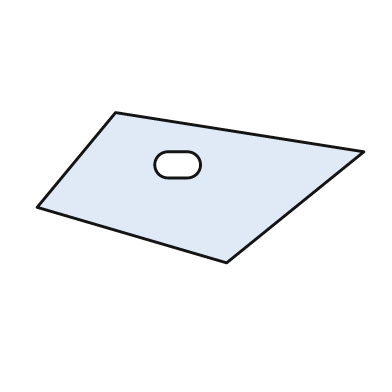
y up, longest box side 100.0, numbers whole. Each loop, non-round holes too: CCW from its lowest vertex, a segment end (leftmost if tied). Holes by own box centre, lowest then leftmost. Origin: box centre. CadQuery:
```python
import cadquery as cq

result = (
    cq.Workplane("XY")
    .moveTo(8.0, -23.0)
    .lineTo(50.0, 11.0)
    .lineTo(-26.0, 23.0)
    .lineTo(-50.0, -6.0)
    .close()
    .moveTo(-10.0, 3.0)
    .lineTo(-4.0, 3.0)
    .threePointArc((0.0, 7.0), (-4.0, 11.0))
    .lineTo(-10.0, 11.0)
    .threePointArc((-14.0, 7.0), (-10.0, 3.0))
    .close()
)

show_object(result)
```